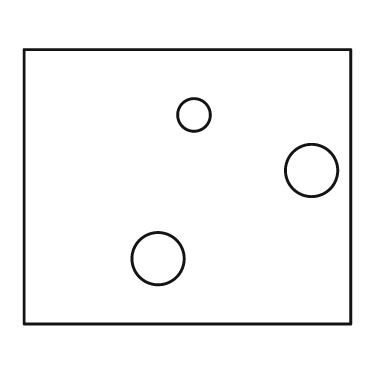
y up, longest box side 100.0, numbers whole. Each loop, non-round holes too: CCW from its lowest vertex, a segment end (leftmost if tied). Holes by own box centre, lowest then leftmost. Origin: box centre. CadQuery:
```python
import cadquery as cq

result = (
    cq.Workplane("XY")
    .moveTo(-50.0, -42.0)
    .lineTo(50.0, -42.0)
    .lineTo(50.0, 42.0)
    .lineTo(-50.0, 42.0)
    .close()
    .moveTo(-9.0, -22.0)
    .circle(8.0)
    .moveTo(38.0, 5.0)
    .circle(8.0)
    .moveTo(2.0, 22.0)
    .circle(5.0)
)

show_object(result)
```